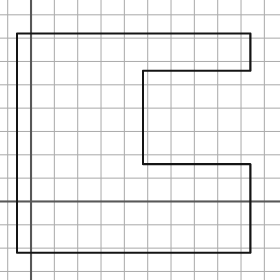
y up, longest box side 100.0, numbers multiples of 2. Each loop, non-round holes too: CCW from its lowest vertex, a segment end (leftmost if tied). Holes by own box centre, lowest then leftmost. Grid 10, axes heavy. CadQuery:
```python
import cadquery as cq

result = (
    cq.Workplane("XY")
    .moveTo(-6.0, -22.0)
    .lineTo(94.0, -22.0)
    .lineTo(94.0, 16.0)
    .lineTo(48.0, 16.0)
    .lineTo(48.0, 56.0)
    .lineTo(94.0, 56.0)
    .lineTo(94.0, 72.0)
    .lineTo(-6.0, 72.0)
    .close()
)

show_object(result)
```